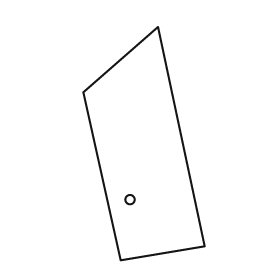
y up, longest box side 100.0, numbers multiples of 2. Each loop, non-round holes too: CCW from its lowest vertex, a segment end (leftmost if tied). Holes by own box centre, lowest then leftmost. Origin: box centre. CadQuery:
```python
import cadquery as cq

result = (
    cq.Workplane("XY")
    .moveTo(-10.0, -50.0)
    .lineTo(26.0, -44.0)
    .lineTo(6.0, 50.0)
    .lineTo(-26.0, 22.0)
    .close()
    .moveTo(-6.0, -24.0)
    .circle(2.0)
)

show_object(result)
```